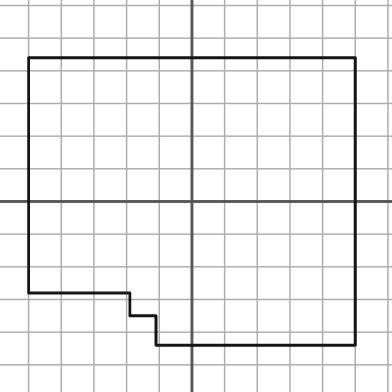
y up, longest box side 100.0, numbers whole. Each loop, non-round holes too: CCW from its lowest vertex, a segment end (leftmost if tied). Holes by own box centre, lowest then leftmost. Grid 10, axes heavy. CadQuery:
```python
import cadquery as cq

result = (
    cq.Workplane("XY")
    .moveTo(-11.0, -44.0)
    .lineTo(50.0, -44.0)
    .lineTo(50.0, 44.0)
    .lineTo(-50.0, 44.0)
    .lineTo(-50.0, -28.0)
    .lineTo(-19.0, -28.0)
    .lineTo(-19.0, -35.0)
    .lineTo(-11.0, -35.0)
    .close()
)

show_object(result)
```